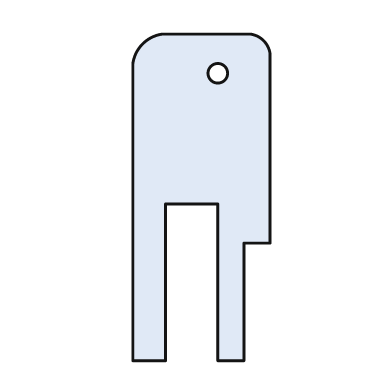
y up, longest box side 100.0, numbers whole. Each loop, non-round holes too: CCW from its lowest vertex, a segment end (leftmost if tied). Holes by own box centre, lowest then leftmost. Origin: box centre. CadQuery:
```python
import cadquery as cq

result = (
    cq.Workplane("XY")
    .moveTo(-21.0, -50.0)
    .lineTo(-11.0, -50.0)
    .lineTo(-11.0, -2.0)
    .lineTo(5.0, -2.0)
    .lineTo(5.0, -50.0)
    .lineTo(13.0, -50.0)
    .lineTo(13.0, -14.0)
    .lineTo(21.0, -14.0)
    .lineTo(21.0, 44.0)
    .threePointArc((19.0, 48.0), (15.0, 50.0))
    .lineTo(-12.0, 50.0)
    .threePointArc((-18.0, 47.0), (-21.0, 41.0))
    .close()
    .moveTo(5.0, 38.0)
    .circle(3.0)
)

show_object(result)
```